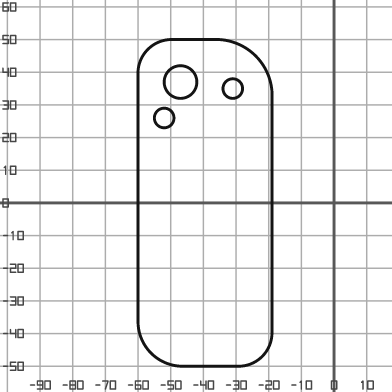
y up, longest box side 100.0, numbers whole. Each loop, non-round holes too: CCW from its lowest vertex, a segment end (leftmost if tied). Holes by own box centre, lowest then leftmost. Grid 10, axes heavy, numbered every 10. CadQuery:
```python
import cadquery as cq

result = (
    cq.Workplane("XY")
    .moveTo(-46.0, -50.0)
    .lineTo(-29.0, -50.0)
    .threePointArc((-22.0, -47.0), (-19.0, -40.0))
    .lineTo(-19.0, 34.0)
    .threePointArc((-24.0, 45.0), (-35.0, 50.0))
    .lineTo(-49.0, 50.0)
    .threePointArc((-57.0, 47.0), (-60.0, 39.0))
    .lineTo(-60.0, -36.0)
    .threePointArc((-56.0, -46.0), (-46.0, -50.0))
    .close()
    .moveTo(-52.0, 26.0)
    .circle(3.0)
    .moveTo(-31.0, 35.0)
    .circle(3.0)
    .moveTo(-47.0, 37.0)
    .circle(5.0)
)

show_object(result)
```